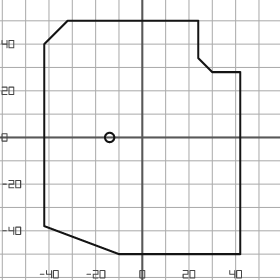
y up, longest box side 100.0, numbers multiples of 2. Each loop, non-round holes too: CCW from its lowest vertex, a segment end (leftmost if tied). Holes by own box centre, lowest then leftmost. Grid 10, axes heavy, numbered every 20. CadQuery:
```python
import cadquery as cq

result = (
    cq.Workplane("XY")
    .moveTo(-10.0, -50.0)
    .lineTo(42.0, -50.0)
    .lineTo(42.0, 28.0)
    .lineTo(30.0, 28.0)
    .lineTo(24.0, 34.0)
    .lineTo(24.0, 50.0)
    .lineTo(-32.0, 50.0)
    .lineTo(-42.0, 40.0)
    .lineTo(-42.0, -38.0)
    .close()
    .moveTo(-14.0, 0.0)
    .circle(2.0)
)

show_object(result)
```